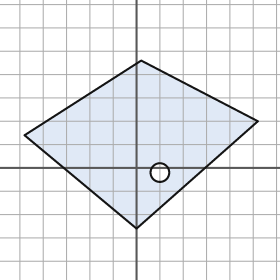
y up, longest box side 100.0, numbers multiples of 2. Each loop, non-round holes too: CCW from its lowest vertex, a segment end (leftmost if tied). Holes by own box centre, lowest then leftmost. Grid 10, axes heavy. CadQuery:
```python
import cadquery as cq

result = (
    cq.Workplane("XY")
    .moveTo(0.0, -26.0)
    .lineTo(52.0, 20.0)
    .lineTo(2.0, 46.0)
    .lineTo(-48.0, 14.0)
    .close()
    .moveTo(10.0, -2.0)
    .circle(4.0)
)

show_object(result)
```